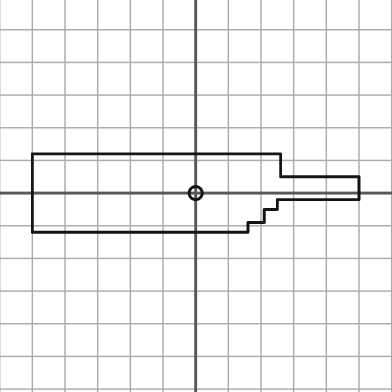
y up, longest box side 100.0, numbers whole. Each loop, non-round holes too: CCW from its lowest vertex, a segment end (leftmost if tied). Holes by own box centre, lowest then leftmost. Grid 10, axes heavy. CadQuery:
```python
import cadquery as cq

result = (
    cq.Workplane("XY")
    .moveTo(-50.0, -12.0)
    .lineTo(16.0, -12.0)
    .lineTo(16.0, -9.0)
    .lineTo(21.0, -9.0)
    .lineTo(21.0, -5.0)
    .lineTo(25.0, -5.0)
    .lineTo(25.0, -2.0)
    .lineTo(50.0, -2.0)
    .lineTo(50.0, 5.0)
    .lineTo(26.0, 5.0)
    .lineTo(26.0, 12.0)
    .lineTo(-50.0, 12.0)
    .close()
    .moveTo(0.0, 0.0)
    .circle(2.0)
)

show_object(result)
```